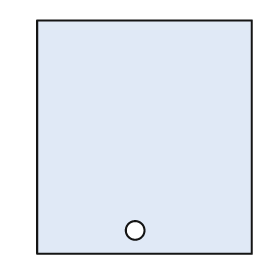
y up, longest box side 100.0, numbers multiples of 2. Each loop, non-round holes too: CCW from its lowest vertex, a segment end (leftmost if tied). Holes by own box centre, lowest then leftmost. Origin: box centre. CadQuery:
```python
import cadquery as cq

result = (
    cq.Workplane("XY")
    .moveTo(-46.0, -50.0)
    .lineTo(46.0, -50.0)
    .lineTo(46.0, 50.0)
    .lineTo(-46.0, 50.0)
    .close()
    .moveTo(-4.0, -40.0)
    .circle(4.0)
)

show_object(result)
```